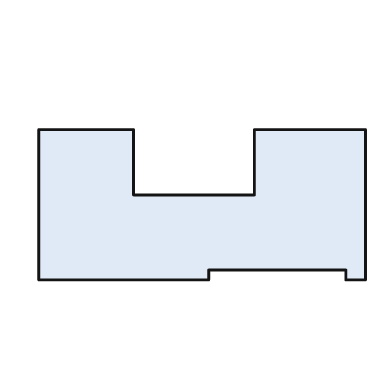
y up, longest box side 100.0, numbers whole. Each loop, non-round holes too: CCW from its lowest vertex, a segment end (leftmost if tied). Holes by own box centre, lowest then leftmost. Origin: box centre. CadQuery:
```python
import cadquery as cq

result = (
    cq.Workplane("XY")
    .moveTo(-50.0, -23.0)
    .lineTo(2.0, -23.0)
    .lineTo(2.0, -20.0)
    .lineTo(44.0, -20.0)
    .lineTo(44.0, -23.0)
    .lineTo(50.0, -23.0)
    .lineTo(50.0, 23.0)
    .lineTo(16.0, 23.0)
    .lineTo(16.0, 3.0)
    .lineTo(-21.0, 3.0)
    .lineTo(-21.0, 23.0)
    .lineTo(-50.0, 23.0)
    .close()
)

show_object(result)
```